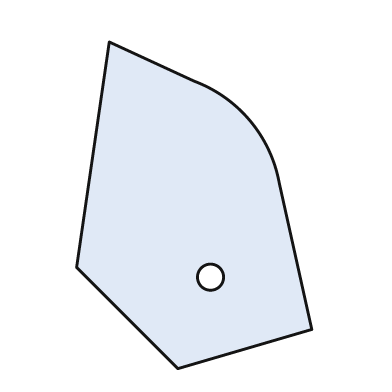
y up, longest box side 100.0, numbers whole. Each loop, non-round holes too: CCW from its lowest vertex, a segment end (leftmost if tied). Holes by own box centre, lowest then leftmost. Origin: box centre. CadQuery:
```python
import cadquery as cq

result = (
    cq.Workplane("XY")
    .moveTo(-5.0, -50.0)
    .lineTo(36.0, -38.0)
    .lineTo(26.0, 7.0)
    .threePointArc((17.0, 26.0), (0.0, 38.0))
    .lineTo(-26.0, 50.0)
    .lineTo(-36.0, -19.0)
    .close()
    .moveTo(5.0, -22.0)
    .circle(4.0)
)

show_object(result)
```